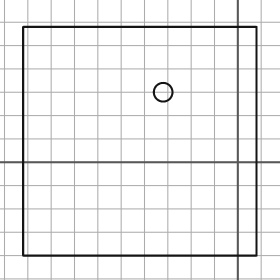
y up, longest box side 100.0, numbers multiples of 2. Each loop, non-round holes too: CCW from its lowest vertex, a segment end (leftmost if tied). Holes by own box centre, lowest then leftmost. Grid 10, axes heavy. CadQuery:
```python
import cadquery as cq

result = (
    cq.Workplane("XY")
    .moveTo(-92.0, -40.0)
    .lineTo(8.0, -40.0)
    .lineTo(8.0, 58.0)
    .lineTo(-92.0, 58.0)
    .close()
    .moveTo(-32.0, 30.0)
    .circle(4.0)
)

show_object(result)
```